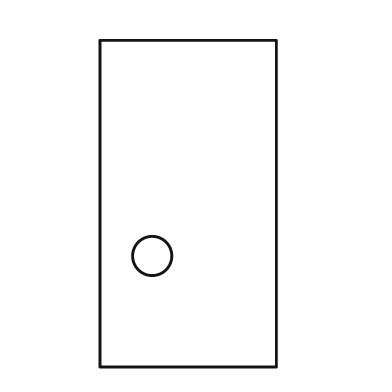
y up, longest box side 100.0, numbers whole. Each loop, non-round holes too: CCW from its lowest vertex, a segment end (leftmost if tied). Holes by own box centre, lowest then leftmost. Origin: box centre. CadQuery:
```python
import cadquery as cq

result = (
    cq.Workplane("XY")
    .moveTo(-27.0, -50.0)
    .lineTo(27.0, -50.0)
    .lineTo(27.0, 50.0)
    .lineTo(-27.0, 50.0)
    .close()
    .moveTo(-11.0, -16.0)
    .circle(6.0)
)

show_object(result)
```